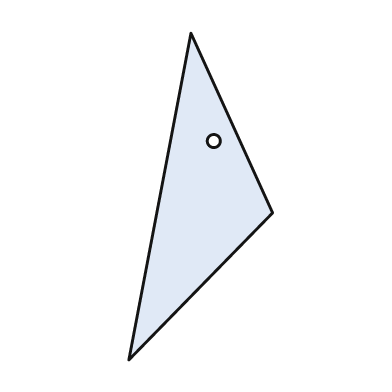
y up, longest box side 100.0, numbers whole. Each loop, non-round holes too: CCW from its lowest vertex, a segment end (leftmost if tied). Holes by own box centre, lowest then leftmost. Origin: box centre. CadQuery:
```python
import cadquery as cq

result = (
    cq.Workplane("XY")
    .moveTo(-22.0, -50.0)
    .lineTo(22.0, -5.0)
    .lineTo(-3.0, 50.0)
    .close()
    .moveTo(4.0, 17.0)
    .circle(2.0)
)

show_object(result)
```